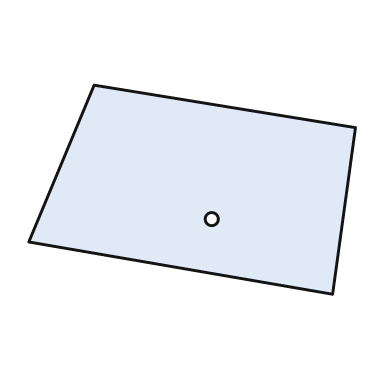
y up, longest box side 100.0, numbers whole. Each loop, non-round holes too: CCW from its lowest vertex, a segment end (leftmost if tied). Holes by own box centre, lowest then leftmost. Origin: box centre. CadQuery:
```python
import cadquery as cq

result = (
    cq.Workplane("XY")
    .moveTo(43.0, -32.0)
    .lineTo(50.0, 19.0)
    .lineTo(-30.0, 32.0)
    .lineTo(-50.0, -16.0)
    .close()
    .moveTo(6.0, -9.0)
    .circle(2.0)
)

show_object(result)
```